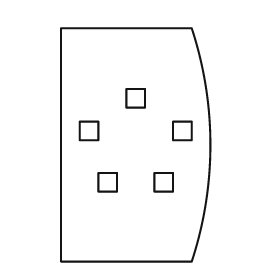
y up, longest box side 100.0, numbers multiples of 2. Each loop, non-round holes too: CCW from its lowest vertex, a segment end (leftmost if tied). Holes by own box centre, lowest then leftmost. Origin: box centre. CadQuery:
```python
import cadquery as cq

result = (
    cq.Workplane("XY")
    .moveTo(-32.0, -50.0)
    .lineTo(24.0, -50.0)
    .threePointArc((32.0, 0.0), (24.0, 50.0))
    .lineTo(-32.0, 50.0)
    .close()
    .moveTo(-16.0, -20.0)
    .lineTo(-8.0, -20.0)
    .lineTo(-8.0, -12.0)
    .lineTo(-16.0, -12.0)
    .close()
    .moveTo(8.0, -20.0)
    .lineTo(16.0, -20.0)
    .lineTo(16.0, -12.0)
    .lineTo(8.0, -12.0)
    .close()
    .moveTo(-24.0, 2.0)
    .lineTo(-16.0, 2.0)
    .lineTo(-16.0, 10.0)
    .lineTo(-24.0, 10.0)
    .close()
    .moveTo(16.0, 2.0)
    .lineTo(24.0, 2.0)
    .lineTo(24.0, 10.0)
    .lineTo(16.0, 10.0)
    .close()
    .moveTo(-4.0, 16.0)
    .lineTo(4.0, 16.0)
    .lineTo(4.0, 24.0)
    .lineTo(-4.0, 24.0)
    .close()
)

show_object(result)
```